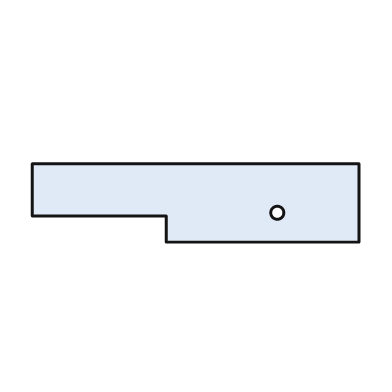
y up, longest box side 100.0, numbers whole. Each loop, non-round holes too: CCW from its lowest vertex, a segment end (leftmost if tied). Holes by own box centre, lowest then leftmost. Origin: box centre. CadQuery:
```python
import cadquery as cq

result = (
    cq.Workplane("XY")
    .moveTo(-9.0, -12.0)
    .lineTo(50.0, -12.0)
    .lineTo(50.0, 12.0)
    .lineTo(-50.0, 12.0)
    .lineTo(-50.0, -4.0)
    .lineTo(-9.0, -4.0)
    .close()
    .moveTo(25.0, -3.0)
    .circle(2.0)
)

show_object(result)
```